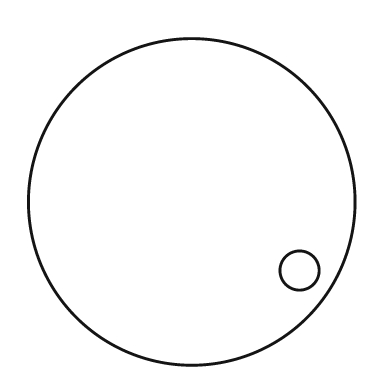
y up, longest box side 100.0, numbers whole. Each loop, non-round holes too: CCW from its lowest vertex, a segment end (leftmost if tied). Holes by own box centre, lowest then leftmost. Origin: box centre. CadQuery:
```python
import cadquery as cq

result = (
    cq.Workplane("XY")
    .moveTo(0.0, 0.0)
    .circle(50.0)
    .moveTo(33.0, -21.0)
    .circle(6.0)
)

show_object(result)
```